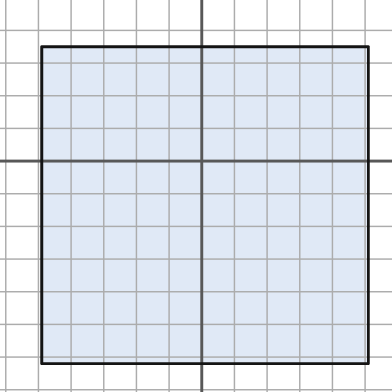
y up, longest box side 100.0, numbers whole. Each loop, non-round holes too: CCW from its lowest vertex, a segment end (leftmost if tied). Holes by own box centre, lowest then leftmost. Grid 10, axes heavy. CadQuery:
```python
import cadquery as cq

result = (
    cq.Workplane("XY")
    .moveTo(-49.0, -62.0)
    .lineTo(51.0, -62.0)
    .lineTo(51.0, 35.0)
    .lineTo(-49.0, 35.0)
    .close()
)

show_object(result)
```